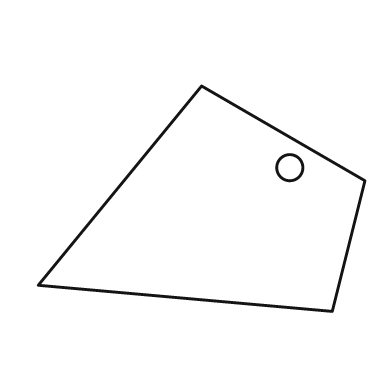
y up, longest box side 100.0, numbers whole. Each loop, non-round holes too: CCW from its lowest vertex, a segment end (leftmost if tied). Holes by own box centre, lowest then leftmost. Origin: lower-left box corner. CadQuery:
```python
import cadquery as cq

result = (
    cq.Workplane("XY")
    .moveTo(90.0, 0.0)
    .lineTo(100.0, 40.0)
    .lineTo(50.0, 69.0)
    .lineTo(0.0, 8.0)
    .close()
    .moveTo(77.0, 44.0)
    .circle(4.0)
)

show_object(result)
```